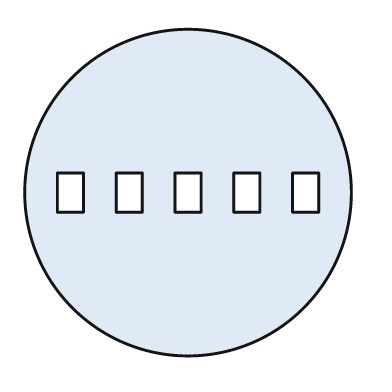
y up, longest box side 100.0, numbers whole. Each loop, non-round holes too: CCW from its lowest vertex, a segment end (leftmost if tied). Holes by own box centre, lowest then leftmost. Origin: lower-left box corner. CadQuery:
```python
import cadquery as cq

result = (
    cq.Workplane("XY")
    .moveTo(50.0, 50.0)
    .circle(50.0)
    .moveTo(10.0, 44.0)
    .lineTo(18.0, 44.0)
    .lineTo(18.0, 56.0)
    .lineTo(10.0, 56.0)
    .close()
    .moveTo(28.0, 44.0)
    .lineTo(36.0, 44.0)
    .lineTo(36.0, 56.0)
    .lineTo(28.0, 56.0)
    .close()
    .moveTo(46.0, 44.0)
    .lineTo(54.0, 44.0)
    .lineTo(54.0, 56.0)
    .lineTo(46.0, 56.0)
    .close()
    .moveTo(64.0, 44.0)
    .lineTo(72.0, 44.0)
    .lineTo(72.0, 56.0)
    .lineTo(64.0, 56.0)
    .close()
    .moveTo(82.0, 44.0)
    .lineTo(90.0, 44.0)
    .lineTo(90.0, 56.0)
    .lineTo(82.0, 56.0)
    .close()
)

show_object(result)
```